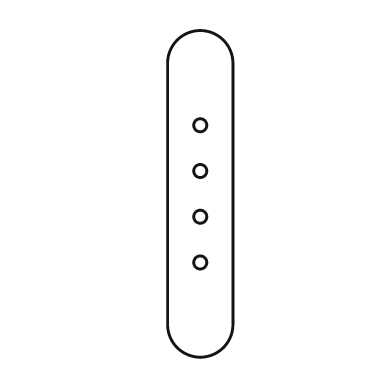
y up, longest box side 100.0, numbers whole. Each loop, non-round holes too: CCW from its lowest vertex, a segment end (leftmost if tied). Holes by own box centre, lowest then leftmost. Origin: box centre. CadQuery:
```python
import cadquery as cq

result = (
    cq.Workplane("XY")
    .moveTo(-10.0, -40.0)
    .threePointArc((0.0, -50.0), (10.0, -40.0))
    .lineTo(10.0, 40.0)
    .threePointArc((0.0, 50.0), (-10.0, 40.0))
    .close()
    .moveTo(0.0, -21.0)
    .circle(2.0)
    .moveTo(0.0, -7.0)
    .circle(2.0)
    .moveTo(0.0, 7.0)
    .circle(2.0)
    .moveTo(0.0, 21.0)
    .circle(2.0)
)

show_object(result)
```